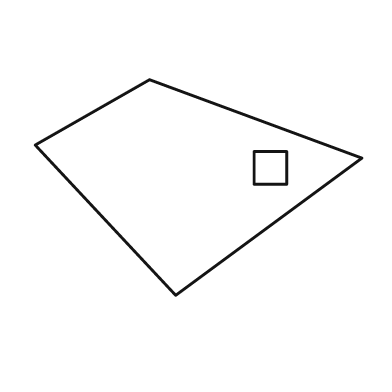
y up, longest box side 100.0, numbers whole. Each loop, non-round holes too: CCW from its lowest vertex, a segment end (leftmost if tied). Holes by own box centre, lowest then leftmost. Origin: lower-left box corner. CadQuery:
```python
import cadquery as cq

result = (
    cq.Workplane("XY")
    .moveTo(43.0, 0.0)
    .lineTo(100.0, 42.0)
    .lineTo(35.0, 66.0)
    .lineTo(0.0, 46.0)
    .close()
    .moveTo(67.0, 34.0)
    .lineTo(77.0, 34.0)
    .lineTo(77.0, 44.0)
    .lineTo(67.0, 44.0)
    .close()
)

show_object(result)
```